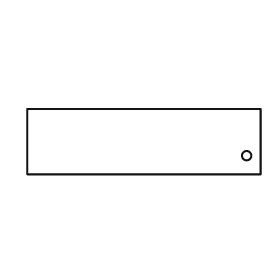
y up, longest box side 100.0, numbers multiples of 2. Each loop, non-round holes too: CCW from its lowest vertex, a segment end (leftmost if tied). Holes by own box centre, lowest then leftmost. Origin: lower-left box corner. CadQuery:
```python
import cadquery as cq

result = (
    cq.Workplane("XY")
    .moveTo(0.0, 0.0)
    .lineTo(100.0, 0.0)
    .lineTo(100.0, 28.0)
    .lineTo(0.0, 28.0)
    .close()
    .moveTo(94.0, 8.0)
    .circle(2.0)
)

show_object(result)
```